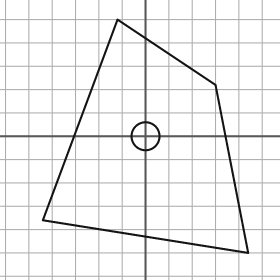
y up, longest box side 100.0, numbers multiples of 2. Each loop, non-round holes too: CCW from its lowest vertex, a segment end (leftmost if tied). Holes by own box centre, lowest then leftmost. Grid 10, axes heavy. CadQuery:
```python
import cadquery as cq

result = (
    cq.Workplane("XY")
    .moveTo(44.0, -50.0)
    .lineTo(30.0, 22.0)
    .lineTo(-12.0, 50.0)
    .lineTo(-44.0, -36.0)
    .close()
    .moveTo(0.0, 0.0)
    .circle(6.0)
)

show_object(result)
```